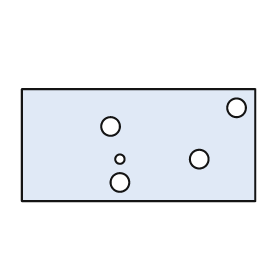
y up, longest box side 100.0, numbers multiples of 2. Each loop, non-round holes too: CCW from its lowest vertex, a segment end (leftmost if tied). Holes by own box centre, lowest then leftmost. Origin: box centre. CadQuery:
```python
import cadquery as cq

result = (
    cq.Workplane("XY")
    .moveTo(-50.0, -24.0)
    .lineTo(50.0, -24.0)
    .lineTo(50.0, 24.0)
    .lineTo(-50.0, 24.0)
    .close()
    .moveTo(-8.0, -16.0)
    .circle(4.0)
    .moveTo(-8.0, -6.0)
    .circle(2.0)
    .moveTo(26.0, -6.0)
    .circle(4.0)
    .moveTo(-12.0, 8.0)
    .circle(4.0)
    .moveTo(42.0, 16.0)
    .circle(4.0)
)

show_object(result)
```